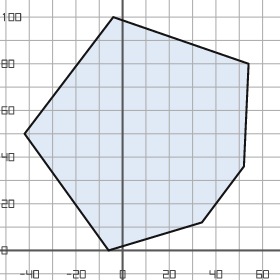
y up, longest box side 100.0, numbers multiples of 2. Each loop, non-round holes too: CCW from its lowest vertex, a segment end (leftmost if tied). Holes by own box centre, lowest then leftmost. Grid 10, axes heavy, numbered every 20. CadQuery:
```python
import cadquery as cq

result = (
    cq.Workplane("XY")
    .moveTo(-6.0, 0.0)
    .lineTo(34.0, 12.0)
    .lineTo(52.0, 36.0)
    .lineTo(54.0, 80.0)
    .lineTo(-4.0, 100.0)
    .lineTo(-42.0, 50.0)
    .close()
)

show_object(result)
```